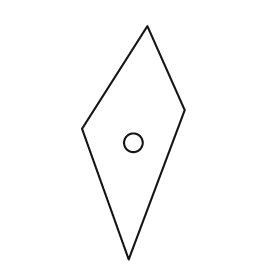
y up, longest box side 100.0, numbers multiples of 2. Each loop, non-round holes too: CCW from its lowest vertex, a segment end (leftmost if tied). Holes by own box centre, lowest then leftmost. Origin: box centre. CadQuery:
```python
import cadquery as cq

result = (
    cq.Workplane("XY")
    .moveTo(-2.0, -50.0)
    .lineTo(22.0, 14.0)
    .lineTo(6.0, 50.0)
    .lineTo(-22.0, 6.0)
    .close()
    .moveTo(0.0, 0.0)
    .circle(4.0)
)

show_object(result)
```